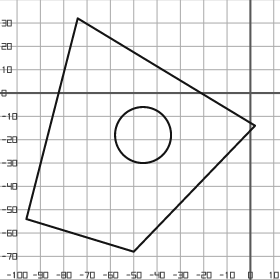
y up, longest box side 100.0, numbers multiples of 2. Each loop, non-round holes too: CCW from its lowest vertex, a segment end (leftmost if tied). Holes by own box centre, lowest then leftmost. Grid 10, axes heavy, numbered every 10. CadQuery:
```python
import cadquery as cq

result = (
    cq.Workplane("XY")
    .moveTo(-50.0, -68.0)
    .lineTo(2.0, -14.0)
    .lineTo(-74.0, 32.0)
    .lineTo(-96.0, -54.0)
    .close()
    .moveTo(-46.0, -18.0)
    .circle(12.0)
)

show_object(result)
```